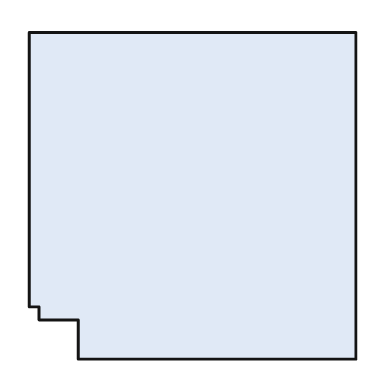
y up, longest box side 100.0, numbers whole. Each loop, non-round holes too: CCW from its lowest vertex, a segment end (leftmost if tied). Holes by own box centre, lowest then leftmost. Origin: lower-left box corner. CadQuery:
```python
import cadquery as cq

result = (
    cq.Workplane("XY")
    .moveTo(15.0, 0.0)
    .lineTo(100.0, 0.0)
    .lineTo(100.0, 100.0)
    .lineTo(0.0, 100.0)
    .lineTo(0.0, 16.0)
    .lineTo(3.0, 16.0)
    .lineTo(3.0, 12.0)
    .lineTo(15.0, 12.0)
    .close()
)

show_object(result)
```